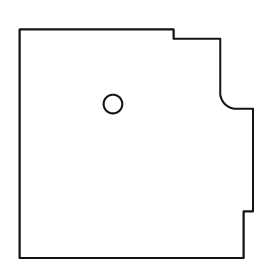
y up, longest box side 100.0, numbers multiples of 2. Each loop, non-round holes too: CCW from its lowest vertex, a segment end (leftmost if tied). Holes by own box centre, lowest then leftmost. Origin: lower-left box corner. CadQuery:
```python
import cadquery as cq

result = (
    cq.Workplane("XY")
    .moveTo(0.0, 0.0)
    .lineTo(96.0, 0.0)
    .lineTo(96.0, 20.0)
    .lineTo(100.0, 20.0)
    .lineTo(100.0, 64.0)
    .lineTo(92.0, 64.0)
    .threePointArc((88.0, 66.0), (86.0, 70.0))
    .lineTo(86.0, 94.0)
    .lineTo(66.0, 94.0)
    .lineTo(66.0, 98.0)
    .lineTo(0.0, 98.0)
    .close()
    .moveTo(40.0, 66.0)
    .circle(4.0)
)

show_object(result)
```